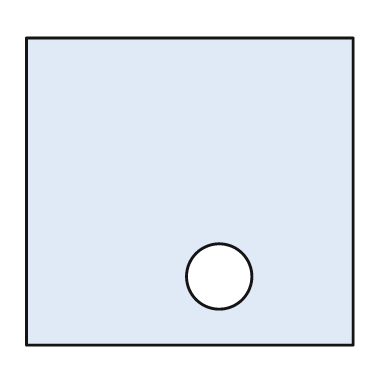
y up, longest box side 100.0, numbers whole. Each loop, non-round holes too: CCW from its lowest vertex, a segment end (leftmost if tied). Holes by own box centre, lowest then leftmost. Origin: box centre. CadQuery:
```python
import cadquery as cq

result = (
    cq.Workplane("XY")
    .moveTo(-50.0, -47.0)
    .lineTo(50.0, -47.0)
    .lineTo(50.0, 47.0)
    .lineTo(-50.0, 47.0)
    .close()
    .moveTo(9.0, -26.0)
    .circle(10.0)
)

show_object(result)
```